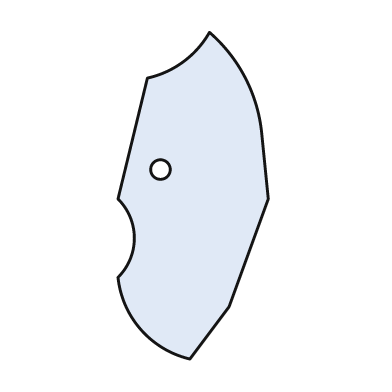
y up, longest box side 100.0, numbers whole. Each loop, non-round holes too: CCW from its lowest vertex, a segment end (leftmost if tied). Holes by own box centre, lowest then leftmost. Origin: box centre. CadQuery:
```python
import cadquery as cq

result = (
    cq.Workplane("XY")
    .moveTo(-1.0, -50.0)
    .lineTo(11.0, -34.0)
    .lineTo(23.0, -1.0)
    .lineTo(21.0, 19.0)
    .threePointArc((16.0, 36.0), (5.0, 50.0))
    .threePointArc((-3.0, 41.0), (-14.0, 36.0))
    .lineTo(-23.0, -1.0)
    .threePointArc((-18.0, -13.0), (-23.0, -25.0))
    .threePointArc((-16.0, -41.0), (-1.0, -50.0))
    .close()
    .moveTo(-10.0, 8.0)
    .circle(3.0)
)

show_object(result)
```